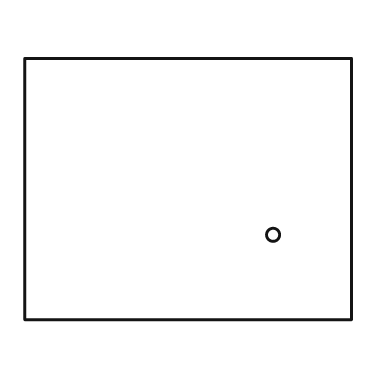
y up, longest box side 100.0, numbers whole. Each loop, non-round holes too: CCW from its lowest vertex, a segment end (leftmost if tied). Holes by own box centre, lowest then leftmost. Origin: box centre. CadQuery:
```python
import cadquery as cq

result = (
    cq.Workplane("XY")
    .moveTo(-50.0, -40.0)
    .lineTo(50.0, -40.0)
    .lineTo(50.0, 40.0)
    .lineTo(-50.0, 40.0)
    .close()
    .moveTo(26.0, -14.0)
    .circle(2.0)
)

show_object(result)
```